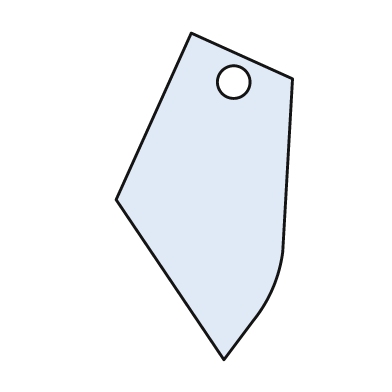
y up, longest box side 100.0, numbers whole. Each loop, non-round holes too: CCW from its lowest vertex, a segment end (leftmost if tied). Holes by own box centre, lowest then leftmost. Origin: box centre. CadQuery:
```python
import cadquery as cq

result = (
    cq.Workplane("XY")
    .moveTo(6.0, -50.0)
    .lineTo(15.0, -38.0)
    .threePointArc((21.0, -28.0), (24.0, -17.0))
    .lineTo(27.0, 36.0)
    .lineTo(-4.0, 50.0)
    .lineTo(-27.0, -1.0)
    .close()
    .moveTo(9.0, 35.0)
    .circle(5.0)
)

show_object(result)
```